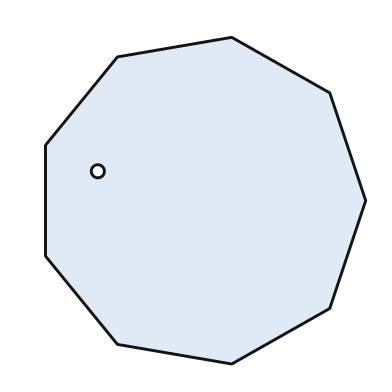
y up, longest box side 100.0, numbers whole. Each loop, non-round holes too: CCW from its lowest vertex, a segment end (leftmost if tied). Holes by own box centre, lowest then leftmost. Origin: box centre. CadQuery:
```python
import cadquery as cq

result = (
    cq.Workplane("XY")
    .moveTo(8.0, -50.0)
    .lineTo(38.0, -33.0)
    .lineTo(49.0, 0.0)
    .lineTo(38.0, 33.0)
    .lineTo(8.0, 50.0)
    .lineTo(-27.0, 44.0)
    .lineTo(-49.0, 17.0)
    .lineTo(-49.0, -17.0)
    .lineTo(-27.0, -44.0)
    .close()
    .moveTo(-33.0, 9.0)
    .circle(2.0)
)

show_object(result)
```